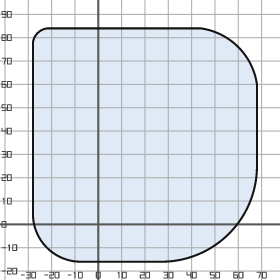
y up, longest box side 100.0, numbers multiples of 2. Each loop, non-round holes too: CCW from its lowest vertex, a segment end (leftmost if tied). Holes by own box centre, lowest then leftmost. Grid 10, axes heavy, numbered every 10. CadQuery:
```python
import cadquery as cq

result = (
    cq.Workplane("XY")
    .moveTo(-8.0, -16.0)
    .lineTo(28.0, -16.0)
    .threePointArc((56.0, -4.0), (68.0, 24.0))
    .lineTo(68.0, 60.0)
    .threePointArc((60.0, 76.0), (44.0, 84.0))
    .lineTo(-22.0, 84.0)
    .threePointArc((-26.0, 82.0), (-28.0, 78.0))
    .lineTo(-28.0, 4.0)
    .threePointArc((-22.0, -10.0), (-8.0, -16.0))
    .close()
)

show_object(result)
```